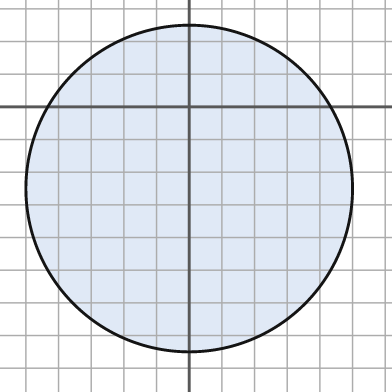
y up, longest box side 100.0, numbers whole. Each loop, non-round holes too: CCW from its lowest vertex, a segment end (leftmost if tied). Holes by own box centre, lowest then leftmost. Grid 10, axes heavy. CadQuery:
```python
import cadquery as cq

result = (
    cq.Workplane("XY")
    .moveTo(0.0, -25.0)
    .circle(50.0)
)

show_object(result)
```